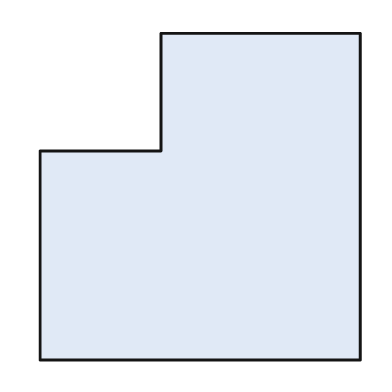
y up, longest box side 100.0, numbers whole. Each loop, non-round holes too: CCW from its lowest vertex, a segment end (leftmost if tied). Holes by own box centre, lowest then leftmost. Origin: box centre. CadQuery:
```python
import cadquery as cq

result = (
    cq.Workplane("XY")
    .moveTo(-49.0, -50.0)
    .lineTo(49.0, -50.0)
    .lineTo(49.0, 50.0)
    .lineTo(-12.0, 50.0)
    .lineTo(-12.0, 14.0)
    .lineTo(-49.0, 14.0)
    .close()
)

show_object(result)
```